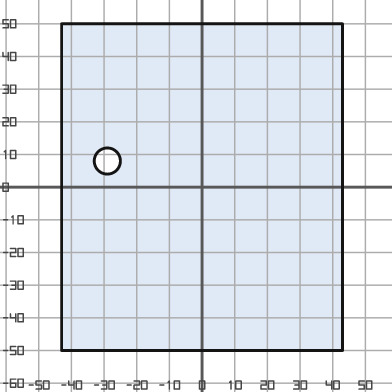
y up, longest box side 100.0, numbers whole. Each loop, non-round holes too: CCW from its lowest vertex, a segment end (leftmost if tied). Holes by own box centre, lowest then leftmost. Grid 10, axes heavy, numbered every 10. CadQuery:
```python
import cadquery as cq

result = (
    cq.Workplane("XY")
    .moveTo(-43.0, -50.0)
    .lineTo(43.0, -50.0)
    .lineTo(43.0, 50.0)
    .lineTo(-43.0, 50.0)
    .close()
    .moveTo(-29.0, 8.0)
    .circle(4.0)
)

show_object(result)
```